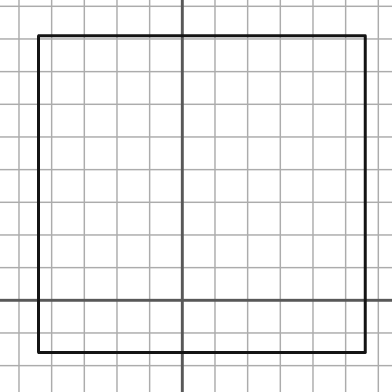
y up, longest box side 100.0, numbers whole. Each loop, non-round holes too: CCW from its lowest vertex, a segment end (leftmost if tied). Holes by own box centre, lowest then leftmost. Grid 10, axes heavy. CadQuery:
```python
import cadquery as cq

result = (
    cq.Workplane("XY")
    .moveTo(-44.0, -16.0)
    .lineTo(56.0, -16.0)
    .lineTo(56.0, 81.0)
    .lineTo(-44.0, 81.0)
    .close()
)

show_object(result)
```